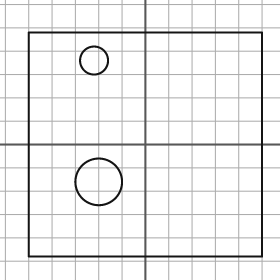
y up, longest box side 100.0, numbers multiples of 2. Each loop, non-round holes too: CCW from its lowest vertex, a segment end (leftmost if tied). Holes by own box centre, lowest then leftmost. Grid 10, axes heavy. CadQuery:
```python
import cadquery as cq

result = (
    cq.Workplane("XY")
    .moveTo(-50.0, -48.0)
    .lineTo(50.0, -48.0)
    .lineTo(50.0, 48.0)
    .lineTo(-50.0, 48.0)
    .close()
    .moveTo(-20.0, -16.0)
    .circle(10.0)
    .moveTo(-22.0, 36.0)
    .circle(6.0)
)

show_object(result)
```